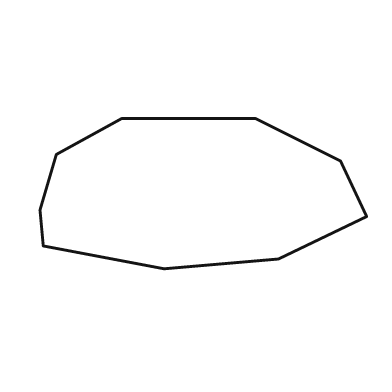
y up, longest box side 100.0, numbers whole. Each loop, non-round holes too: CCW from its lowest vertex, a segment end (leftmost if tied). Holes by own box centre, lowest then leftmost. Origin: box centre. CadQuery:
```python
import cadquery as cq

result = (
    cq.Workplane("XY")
    .moveTo(-12.0, -23.0)
    .lineTo(23.0, -20.0)
    .lineTo(50.0, -7.0)
    .lineTo(42.0, 10.0)
    .lineTo(16.0, 23.0)
    .lineTo(-25.0, 23.0)
    .lineTo(-45.0, 12.0)
    .lineTo(-50.0, -5.0)
    .lineTo(-49.0, -16.0)
    .close()
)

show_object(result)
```